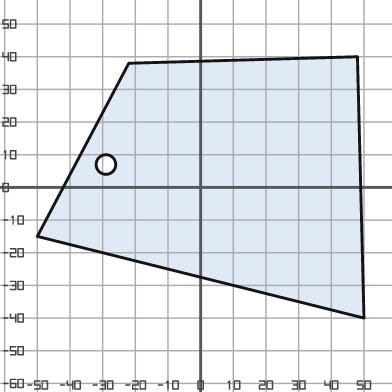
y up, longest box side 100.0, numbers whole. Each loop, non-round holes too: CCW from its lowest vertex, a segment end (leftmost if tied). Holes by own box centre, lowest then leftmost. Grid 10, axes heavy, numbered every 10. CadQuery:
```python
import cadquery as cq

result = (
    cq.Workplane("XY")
    .moveTo(50.0, -40.0)
    .lineTo(48.0, 40.0)
    .lineTo(-22.0, 38.0)
    .lineTo(-50.0, -15.0)
    .close()
    .moveTo(-29.0, 7.0)
    .circle(3.0)
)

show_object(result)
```